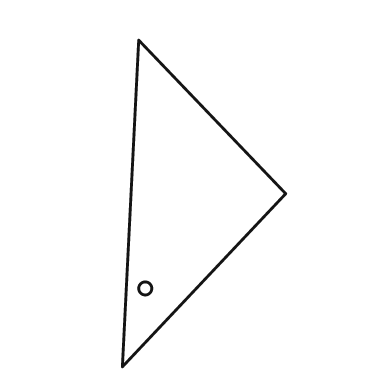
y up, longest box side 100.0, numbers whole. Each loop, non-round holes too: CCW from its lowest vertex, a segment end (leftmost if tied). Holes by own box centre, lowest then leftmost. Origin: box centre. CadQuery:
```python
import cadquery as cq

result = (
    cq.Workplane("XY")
    .moveTo(-25.0, -50.0)
    .lineTo(25.0, 3.0)
    .lineTo(-20.0, 50.0)
    .close()
    .moveTo(-18.0, -26.0)
    .circle(2.0)
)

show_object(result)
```